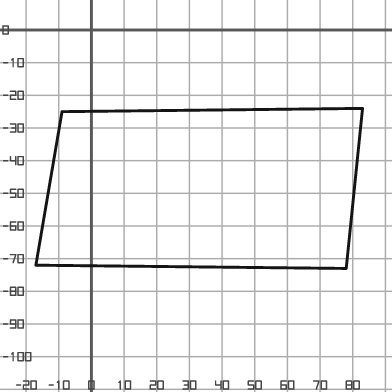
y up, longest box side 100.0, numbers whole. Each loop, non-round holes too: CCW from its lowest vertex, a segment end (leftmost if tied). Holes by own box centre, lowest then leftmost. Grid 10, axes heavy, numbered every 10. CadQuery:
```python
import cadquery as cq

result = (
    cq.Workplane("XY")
    .moveTo(78.0, -73.0)
    .lineTo(83.0, -24.0)
    .lineTo(-9.0, -25.0)
    .lineTo(-17.0, -72.0)
    .close()
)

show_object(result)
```